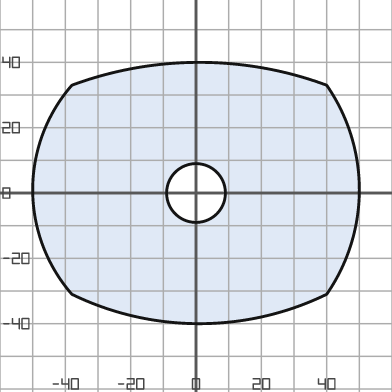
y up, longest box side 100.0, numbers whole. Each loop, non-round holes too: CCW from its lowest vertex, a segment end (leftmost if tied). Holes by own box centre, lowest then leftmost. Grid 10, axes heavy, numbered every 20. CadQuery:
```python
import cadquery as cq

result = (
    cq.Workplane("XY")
    .moveTo(-38.0, -31.0)
    .threePointArc((1.0, -40.0), (40.0, -31.0))
    .threePointArc((50.0, 1.0), (40.0, 33.0))
    .threePointArc((1.0, 40.0), (-38.0, 33.0))
    .threePointArc((-50.0, 1.0), (-38.0, -31.0))
    .close()
    .moveTo(0.0, 0.0)
    .circle(9.0)
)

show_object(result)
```